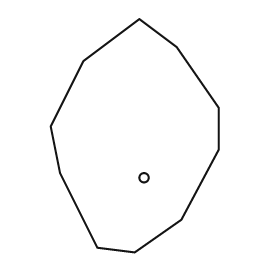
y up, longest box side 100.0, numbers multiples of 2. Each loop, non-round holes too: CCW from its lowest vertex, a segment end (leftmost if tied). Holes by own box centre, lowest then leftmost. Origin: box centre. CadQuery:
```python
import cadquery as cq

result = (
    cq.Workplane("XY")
    .moveTo(0.0, -50.0)
    .lineTo(20.0, -36.0)
    .lineTo(36.0, -6.0)
    .lineTo(36.0, 12.0)
    .lineTo(18.0, 38.0)
    .lineTo(2.0, 50.0)
    .lineTo(-22.0, 32.0)
    .lineTo(-36.0, 4.0)
    .lineTo(-32.0, -16.0)
    .lineTo(-16.0, -48.0)
    .close()
    .moveTo(4.0, -18.0)
    .circle(2.0)
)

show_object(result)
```